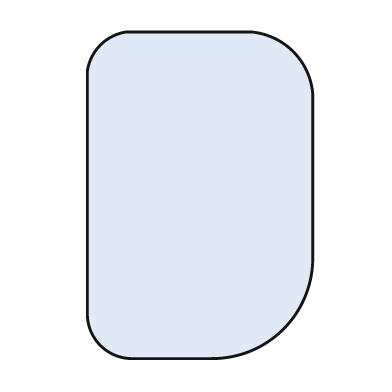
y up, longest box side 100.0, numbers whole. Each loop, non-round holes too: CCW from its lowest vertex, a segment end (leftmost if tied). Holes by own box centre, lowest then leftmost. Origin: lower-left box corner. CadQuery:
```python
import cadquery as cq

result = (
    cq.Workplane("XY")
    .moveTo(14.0, 0.0)
    .lineTo(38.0, 0.0)
    .threePointArc((60.0, 9.0), (69.0, 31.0))
    .lineTo(69.0, 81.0)
    .threePointArc((63.0, 94.0), (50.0, 100.0))
    .lineTo(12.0, 100.0)
    .threePointArc((4.0, 96.0), (0.0, 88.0))
    .lineTo(0.0, 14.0)
    .threePointArc((4.0, 4.0), (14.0, 0.0))
    .close()
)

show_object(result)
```